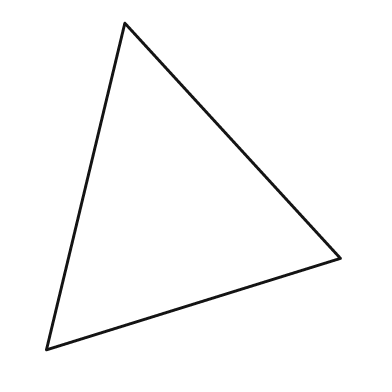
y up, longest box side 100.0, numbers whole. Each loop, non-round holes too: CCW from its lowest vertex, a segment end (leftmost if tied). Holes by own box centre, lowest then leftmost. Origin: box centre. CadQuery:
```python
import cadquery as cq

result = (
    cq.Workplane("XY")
    .moveTo(-45.0, -50.0)
    .lineTo(45.0, -22.0)
    .lineTo(-21.0, 50.0)
    .close()
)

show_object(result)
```